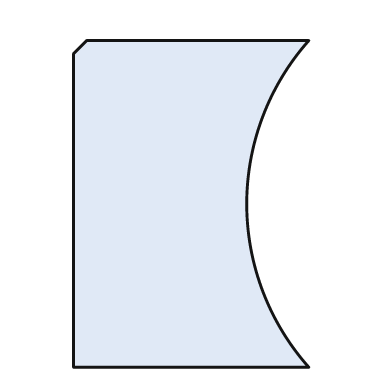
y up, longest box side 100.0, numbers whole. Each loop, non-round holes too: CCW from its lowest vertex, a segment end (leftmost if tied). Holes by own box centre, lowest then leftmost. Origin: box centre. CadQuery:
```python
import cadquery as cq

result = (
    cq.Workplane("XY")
    .moveTo(-36.0, -50.0)
    .lineTo(36.0, -50.0)
    .threePointArc((17.0, 0.0), (36.0, 50.0))
    .lineTo(-32.0, 50.0)
    .lineTo(-36.0, 46.0)
    .close()
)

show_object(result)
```